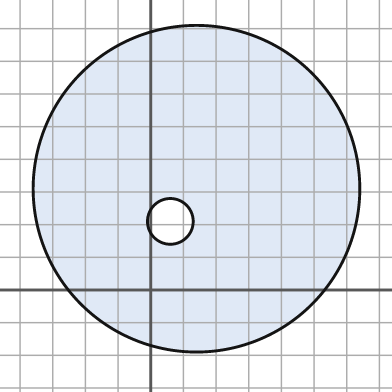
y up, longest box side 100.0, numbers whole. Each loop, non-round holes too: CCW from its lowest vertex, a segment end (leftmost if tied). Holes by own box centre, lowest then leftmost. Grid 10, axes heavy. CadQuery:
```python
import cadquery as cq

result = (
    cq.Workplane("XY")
    .moveTo(14.0, 31.0)
    .circle(50.0)
    .moveTo(6.0, 21.0)
    .circle(7.0)
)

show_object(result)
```